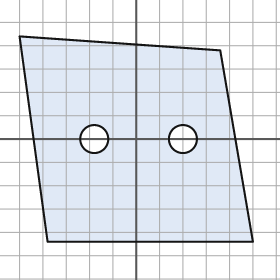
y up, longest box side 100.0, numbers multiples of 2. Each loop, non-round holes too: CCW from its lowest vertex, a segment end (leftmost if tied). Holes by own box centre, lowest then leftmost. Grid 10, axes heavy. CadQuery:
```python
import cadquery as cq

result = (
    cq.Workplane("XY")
    .moveTo(-38.0, -44.0)
    .lineTo(50.0, -44.0)
    .lineTo(36.0, 38.0)
    .lineTo(-50.0, 44.0)
    .close()
    .moveTo(-18.0, 0.0)
    .circle(6.0)
    .moveTo(20.0, 0.0)
    .circle(6.0)
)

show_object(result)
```